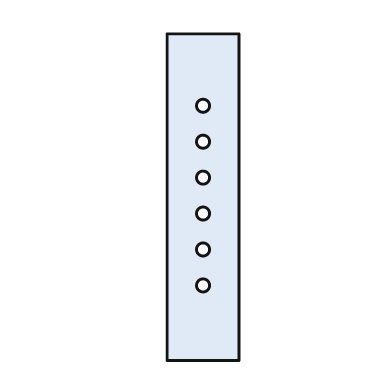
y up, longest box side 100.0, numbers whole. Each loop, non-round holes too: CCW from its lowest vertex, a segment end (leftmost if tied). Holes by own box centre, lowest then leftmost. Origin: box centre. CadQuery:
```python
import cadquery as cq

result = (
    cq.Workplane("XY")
    .moveTo(-11.0, -50.0)
    .lineTo(11.0, -50.0)
    .lineTo(11.0, 50.0)
    .lineTo(-11.0, 50.0)
    .close()
    .moveTo(0.0, -27.0)
    .circle(2.0)
    .moveTo(0.0, -16.0)
    .circle(2.0)
    .moveTo(0.0, -5.0)
    .circle(2.0)
    .moveTo(0.0, 6.0)
    .circle(2.0)
    .moveTo(0.0, 17.0)
    .circle(2.0)
    .moveTo(0.0, 28.0)
    .circle(2.0)
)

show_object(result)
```